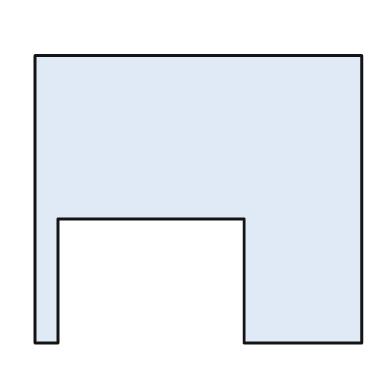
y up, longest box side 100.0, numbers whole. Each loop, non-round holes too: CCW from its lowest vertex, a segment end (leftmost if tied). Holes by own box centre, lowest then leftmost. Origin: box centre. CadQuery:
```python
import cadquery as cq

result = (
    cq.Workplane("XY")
    .moveTo(-50.0, -44.0)
    .lineTo(-43.0, -44.0)
    .lineTo(-43.0, -6.0)
    .lineTo(14.0, -6.0)
    .lineTo(14.0, -44.0)
    .lineTo(50.0, -44.0)
    .lineTo(50.0, 44.0)
    .lineTo(-50.0, 44.0)
    .close()
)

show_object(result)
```